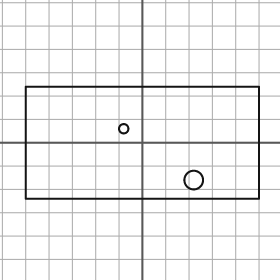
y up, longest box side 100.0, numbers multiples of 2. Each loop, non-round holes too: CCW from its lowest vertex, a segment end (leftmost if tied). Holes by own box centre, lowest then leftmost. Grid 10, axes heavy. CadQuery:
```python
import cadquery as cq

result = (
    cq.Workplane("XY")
    .moveTo(-50.0, -24.0)
    .lineTo(50.0, -24.0)
    .lineTo(50.0, 24.0)
    .lineTo(-50.0, 24.0)
    .close()
    .moveTo(22.0, -16.0)
    .circle(4.0)
    .moveTo(-8.0, 6.0)
    .circle(2.0)
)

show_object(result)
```